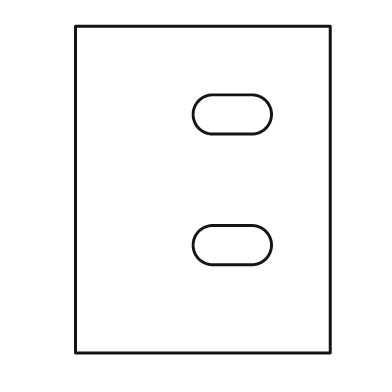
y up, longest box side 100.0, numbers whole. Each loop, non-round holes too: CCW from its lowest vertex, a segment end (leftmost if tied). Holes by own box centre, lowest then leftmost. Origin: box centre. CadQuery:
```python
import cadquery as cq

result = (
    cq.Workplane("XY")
    .moveTo(-39.0, -50.0)
    .lineTo(39.0, -50.0)
    .lineTo(39.0, 50.0)
    .lineTo(-39.0, 50.0)
    .close()
    .moveTo(3.0, -23.0)
    .lineTo(15.0, -23.0)
    .threePointArc((21.0, -17.0), (15.0, -11.0))
    .lineTo(3.0, -11.0)
    .threePointArc((-3.0, -17.0), (3.0, -23.0))
    .close()
    .moveTo(3.0, 17.0)
    .lineTo(15.0, 17.0)
    .threePointArc((21.0, 23.0), (15.0, 29.0))
    .lineTo(3.0, 29.0)
    .threePointArc((-3.0, 23.0), (3.0, 17.0))
    .close()
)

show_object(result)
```